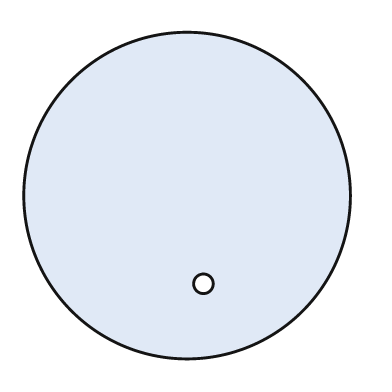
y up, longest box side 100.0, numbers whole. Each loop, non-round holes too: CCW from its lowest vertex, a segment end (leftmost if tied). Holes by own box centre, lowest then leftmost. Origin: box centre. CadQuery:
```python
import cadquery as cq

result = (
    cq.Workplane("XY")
    .moveTo(0.0, 0.0)
    .circle(50.0)
    .moveTo(5.0, -27.0)
    .circle(3.0)
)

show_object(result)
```